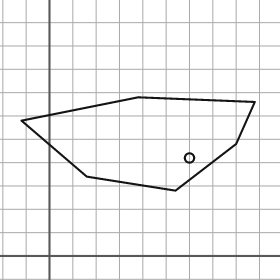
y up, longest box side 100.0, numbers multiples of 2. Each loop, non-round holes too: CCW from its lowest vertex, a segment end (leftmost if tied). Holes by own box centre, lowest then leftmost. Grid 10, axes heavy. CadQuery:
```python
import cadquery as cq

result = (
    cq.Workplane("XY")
    .moveTo(54.0, 28.0)
    .lineTo(80.0, 48.0)
    .lineTo(88.0, 66.0)
    .lineTo(38.0, 68.0)
    .lineTo(-12.0, 58.0)
    .lineTo(16.0, 34.0)
    .close()
    .moveTo(60.0, 42.0)
    .circle(2.0)
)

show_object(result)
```